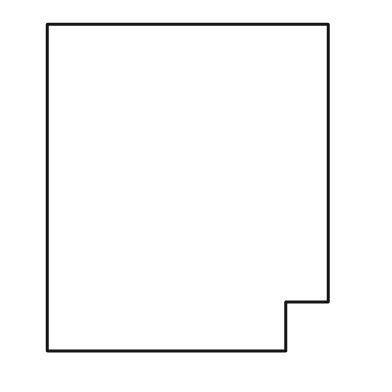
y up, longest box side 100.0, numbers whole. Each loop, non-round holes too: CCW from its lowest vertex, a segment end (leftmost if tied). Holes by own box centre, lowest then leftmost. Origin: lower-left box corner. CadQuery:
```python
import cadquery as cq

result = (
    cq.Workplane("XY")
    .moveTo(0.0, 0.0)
    .lineTo(73.0, 0.0)
    .lineTo(73.0, 15.0)
    .lineTo(86.0, 15.0)
    .lineTo(86.0, 100.0)
    .lineTo(0.0, 100.0)
    .close()
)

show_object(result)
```